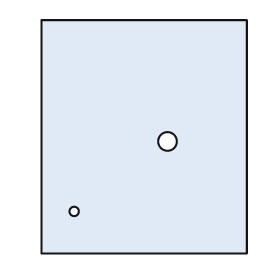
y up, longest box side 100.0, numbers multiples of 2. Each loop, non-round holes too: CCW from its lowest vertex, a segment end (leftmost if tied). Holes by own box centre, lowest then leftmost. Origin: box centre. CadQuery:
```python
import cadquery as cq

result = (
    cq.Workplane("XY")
    .moveTo(-44.0, -50.0)
    .lineTo(44.0, -50.0)
    .lineTo(44.0, 50.0)
    .lineTo(-44.0, 50.0)
    .close()
    .moveTo(-30.0, -32.0)
    .circle(2.0)
    .moveTo(10.0, -2.0)
    .circle(4.0)
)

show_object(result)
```